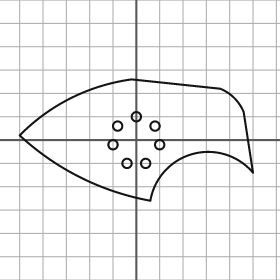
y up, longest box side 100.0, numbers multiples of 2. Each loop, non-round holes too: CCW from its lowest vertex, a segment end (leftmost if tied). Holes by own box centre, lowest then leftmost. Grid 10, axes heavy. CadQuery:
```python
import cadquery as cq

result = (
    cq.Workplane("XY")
    .moveTo(6.0, -26.0)
    .threePointArc((24.0, -6.0), (50.0, -14.0))
    .lineTo(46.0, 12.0)
    .threePointArc((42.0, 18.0), (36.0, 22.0))
    .lineTo(-2.0, 26.0)
    .threePointArc((-28.0, 18.0), (-50.0, 2.0))
    .threePointArc((-24.0, -16.0), (6.0, -26.0))
    .close()
    .moveTo(-4.0, -10.0)
    .circle(2.0)
    .moveTo(4.0, -10.0)
    .circle(2.0)
    .moveTo(-10.0, -2.0)
    .circle(2.0)
    .moveTo(10.0, -2.0)
    .circle(2.0)
    .moveTo(-8.0, 6.0)
    .circle(2.0)
    .moveTo(8.0, 6.0)
    .circle(2.0)
    .moveTo(0.0, 10.0)
    .circle(2.0)
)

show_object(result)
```